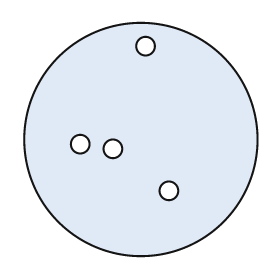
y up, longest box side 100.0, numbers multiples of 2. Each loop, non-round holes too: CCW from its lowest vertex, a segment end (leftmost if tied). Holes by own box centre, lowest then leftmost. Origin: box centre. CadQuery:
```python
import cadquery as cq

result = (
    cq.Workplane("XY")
    .moveTo(0.0, 0.0)
    .circle(50.0)
    .moveTo(12.0, -22.0)
    .circle(4.0)
    .moveTo(-12.0, -4.0)
    .circle(4.0)
    .moveTo(-26.0, -2.0)
    .circle(4.0)
    .moveTo(2.0, 40.0)
    .circle(4.0)
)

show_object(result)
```